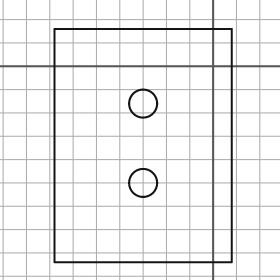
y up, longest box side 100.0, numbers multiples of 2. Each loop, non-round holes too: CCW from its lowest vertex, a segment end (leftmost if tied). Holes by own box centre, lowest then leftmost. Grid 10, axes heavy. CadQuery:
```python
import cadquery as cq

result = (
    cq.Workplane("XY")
    .moveTo(-68.0, -84.0)
    .lineTo(8.0, -84.0)
    .lineTo(8.0, 16.0)
    .lineTo(-68.0, 16.0)
    .close()
    .moveTo(-30.0, -50.0)
    .circle(6.0)
    .moveTo(-30.0, -16.0)
    .circle(6.0)
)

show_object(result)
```